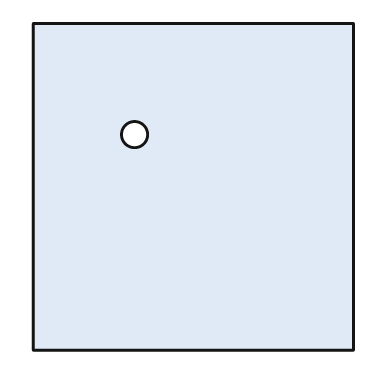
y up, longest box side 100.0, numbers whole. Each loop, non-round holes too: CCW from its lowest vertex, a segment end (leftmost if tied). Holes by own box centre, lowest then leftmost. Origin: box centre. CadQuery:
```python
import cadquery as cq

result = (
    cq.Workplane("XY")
    .moveTo(-49.0, -50.0)
    .lineTo(49.0, -50.0)
    .lineTo(49.0, 50.0)
    .lineTo(-49.0, 50.0)
    .close()
    .moveTo(-18.0, 16.0)
    .circle(4.0)
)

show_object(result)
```